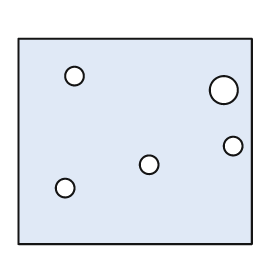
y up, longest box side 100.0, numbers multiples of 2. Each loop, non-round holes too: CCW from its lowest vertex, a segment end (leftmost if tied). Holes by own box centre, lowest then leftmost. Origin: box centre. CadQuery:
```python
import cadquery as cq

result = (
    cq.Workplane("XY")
    .moveTo(-50.0, -44.0)
    .lineTo(50.0, -44.0)
    .lineTo(50.0, 44.0)
    .lineTo(-50.0, 44.0)
    .close()
    .moveTo(-30.0, -20.0)
    .circle(4.0)
    .moveTo(6.0, -10.0)
    .circle(4.0)
    .moveTo(42.0, -2.0)
    .circle(4.0)
    .moveTo(38.0, 22.0)
    .circle(6.0)
    .moveTo(-26.0, 28.0)
    .circle(4.0)
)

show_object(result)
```